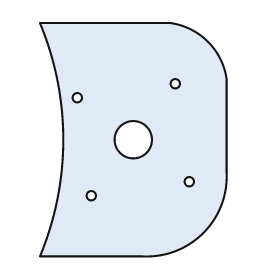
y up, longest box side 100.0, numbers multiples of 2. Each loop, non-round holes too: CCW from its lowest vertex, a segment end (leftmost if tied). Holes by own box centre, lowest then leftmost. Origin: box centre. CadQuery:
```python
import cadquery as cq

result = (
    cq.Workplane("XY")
    .moveTo(-40.0, -50.0)
    .lineTo(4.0, -50.0)
    .threePointArc((30.0, -40.0), (40.0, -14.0))
    .lineTo(40.0, 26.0)
    .threePointArc((32.0, 42.0), (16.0, 50.0))
    .lineTo(-40.0, 50.0)
    .threePointArc((-30.0, 0.0), (-40.0, -50.0))
    .close()
    .moveTo(-18.0, -24.0)
    .circle(2.0)
    .moveTo(24.0, -18.0)
    .circle(2.0)
    .moveTo(0.0, 0.0)
    .circle(8.0)
    .moveTo(-24.0, 18.0)
    .circle(2.0)
    .moveTo(18.0, 24.0)
    .circle(2.0)
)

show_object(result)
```